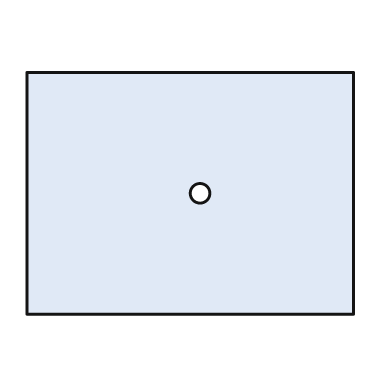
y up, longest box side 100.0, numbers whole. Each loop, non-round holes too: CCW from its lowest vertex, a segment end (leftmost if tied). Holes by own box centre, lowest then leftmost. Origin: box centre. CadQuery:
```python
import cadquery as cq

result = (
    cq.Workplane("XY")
    .moveTo(-50.0, -37.0)
    .lineTo(50.0, -37.0)
    .lineTo(50.0, 37.0)
    .lineTo(-50.0, 37.0)
    .close()
    .moveTo(3.0, 0.0)
    .circle(3.0)
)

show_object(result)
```